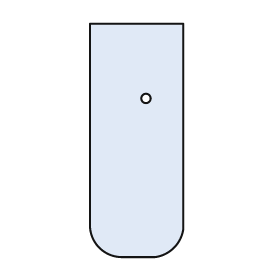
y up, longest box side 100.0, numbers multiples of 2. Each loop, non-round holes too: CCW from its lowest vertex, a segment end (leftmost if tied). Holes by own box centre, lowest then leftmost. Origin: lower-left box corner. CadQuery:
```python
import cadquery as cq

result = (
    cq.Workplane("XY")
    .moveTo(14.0, 0.0)
    .lineTo(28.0, 0.0)
    .threePointArc((36.0, 4.0), (40.0, 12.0))
    .lineTo(40.0, 100.0)
    .lineTo(0.0, 100.0)
    .lineTo(0.0, 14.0)
    .threePointArc((4.0, 4.0), (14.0, 0.0))
    .close()
    .moveTo(24.0, 68.0)
    .circle(2.0)
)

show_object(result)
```